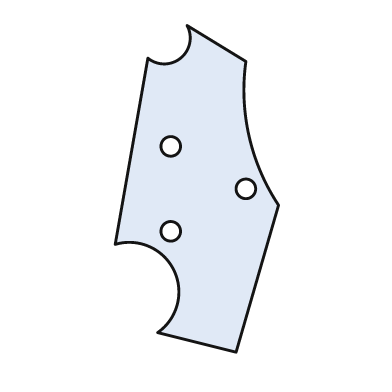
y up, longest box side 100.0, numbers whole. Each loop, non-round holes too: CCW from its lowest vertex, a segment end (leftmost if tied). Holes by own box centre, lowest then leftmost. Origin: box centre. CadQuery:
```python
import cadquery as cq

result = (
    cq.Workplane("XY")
    .moveTo(12.0, -50.0)
    .lineTo(25.0, -5.0)
    .threePointArc((16.0, 16.0), (15.0, 39.0))
    .lineTo(-3.0, 50.0)
    .threePointArc((-5.0, 40.0), (-15.0, 40.0))
    .lineTo(-25.0, -17.0)
    .threePointArc((-7.0, -25.0), (-12.0, -44.0))
    .close()
    .moveTo(-8.0, -13.0)
    .circle(3.0)
    .moveTo(15.0, 0.0)
    .circle(3.0)
    .moveTo(-8.0, 13.0)
    .circle(3.0)
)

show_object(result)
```